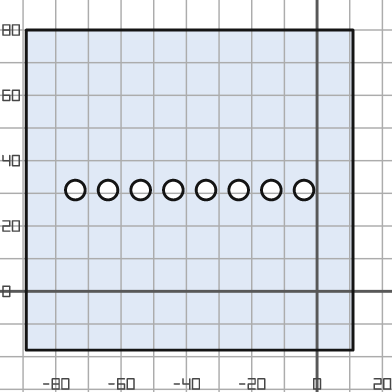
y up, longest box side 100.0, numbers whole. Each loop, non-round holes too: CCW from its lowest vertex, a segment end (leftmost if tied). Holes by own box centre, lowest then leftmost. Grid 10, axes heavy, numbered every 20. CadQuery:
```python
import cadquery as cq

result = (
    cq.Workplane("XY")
    .moveTo(-89.0, -18.0)
    .lineTo(11.0, -18.0)
    .lineTo(11.0, 80.0)
    .lineTo(-89.0, 80.0)
    .close()
    .moveTo(-74.0, 31.0)
    .circle(3.0)
    .moveTo(-64.0, 31.0)
    .circle(3.0)
    .moveTo(-54.0, 31.0)
    .circle(3.0)
    .moveTo(-44.0, 31.0)
    .circle(3.0)
    .moveTo(-34.0, 31.0)
    .circle(3.0)
    .moveTo(-24.0, 31.0)
    .circle(3.0)
    .moveTo(-14.0, 31.0)
    .circle(3.0)
    .moveTo(-4.0, 31.0)
    .circle(3.0)
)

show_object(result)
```